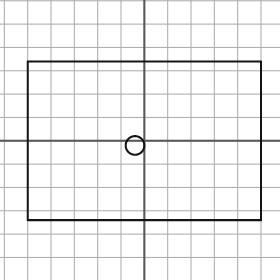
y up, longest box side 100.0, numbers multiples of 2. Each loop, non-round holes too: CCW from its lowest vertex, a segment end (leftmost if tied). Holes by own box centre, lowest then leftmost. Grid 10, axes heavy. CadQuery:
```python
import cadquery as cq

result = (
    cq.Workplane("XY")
    .moveTo(-50.0, -34.0)
    .lineTo(50.0, -34.0)
    .lineTo(50.0, 34.0)
    .lineTo(-50.0, 34.0)
    .close()
    .moveTo(-4.0, -2.0)
    .circle(4.0)
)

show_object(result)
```